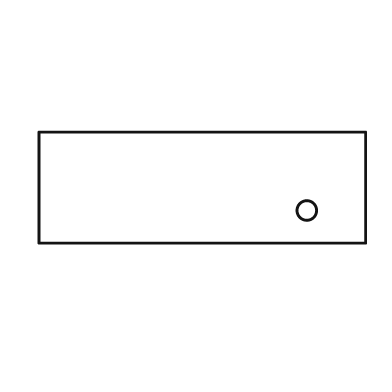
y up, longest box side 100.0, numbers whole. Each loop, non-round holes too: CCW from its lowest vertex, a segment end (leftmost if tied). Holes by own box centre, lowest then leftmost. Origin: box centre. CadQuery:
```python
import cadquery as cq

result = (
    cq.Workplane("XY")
    .moveTo(-50.0, -17.0)
    .lineTo(50.0, -17.0)
    .lineTo(50.0, 17.0)
    .lineTo(-50.0, 17.0)
    .close()
    .moveTo(32.0, -7.0)
    .circle(3.0)
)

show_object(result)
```